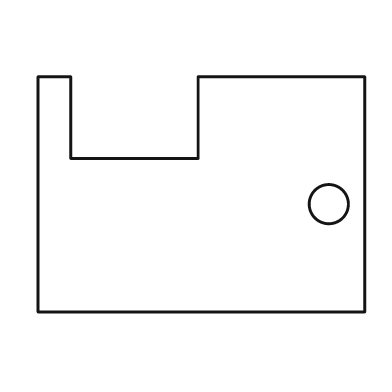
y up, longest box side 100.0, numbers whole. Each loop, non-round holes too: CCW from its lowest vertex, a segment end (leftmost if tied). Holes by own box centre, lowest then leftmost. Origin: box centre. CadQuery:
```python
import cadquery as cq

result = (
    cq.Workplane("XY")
    .moveTo(-50.0, -36.0)
    .lineTo(50.0, -36.0)
    .lineTo(50.0, 36.0)
    .lineTo(-1.0, 36.0)
    .lineTo(-1.0, 11.0)
    .lineTo(-40.0, 11.0)
    .lineTo(-40.0, 36.0)
    .lineTo(-50.0, 36.0)
    .close()
    .moveTo(39.0, -3.0)
    .circle(6.0)
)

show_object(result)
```